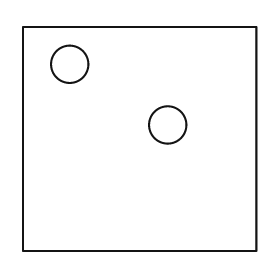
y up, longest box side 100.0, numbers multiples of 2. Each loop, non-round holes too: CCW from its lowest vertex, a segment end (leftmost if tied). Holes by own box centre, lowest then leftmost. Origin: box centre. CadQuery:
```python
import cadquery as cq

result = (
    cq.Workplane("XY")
    .moveTo(-50.0, -48.0)
    .lineTo(50.0, -48.0)
    .lineTo(50.0, 48.0)
    .lineTo(-50.0, 48.0)
    .close()
    .moveTo(12.0, 6.0)
    .circle(8.0)
    .moveTo(-30.0, 32.0)
    .circle(8.0)
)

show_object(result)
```